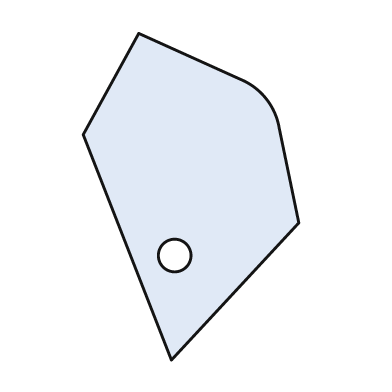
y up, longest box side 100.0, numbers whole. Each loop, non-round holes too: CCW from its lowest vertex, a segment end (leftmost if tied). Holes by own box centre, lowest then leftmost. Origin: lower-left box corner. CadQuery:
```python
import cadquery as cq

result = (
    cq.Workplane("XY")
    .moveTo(27.0, 0.0)
    .lineTo(66.0, 42.0)
    .lineTo(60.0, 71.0)
    .threePointArc((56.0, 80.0), (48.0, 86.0))
    .lineTo(17.0, 100.0)
    .lineTo(0.0, 69.0)
    .close()
    .moveTo(28.0, 32.0)
    .circle(5.0)
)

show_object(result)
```